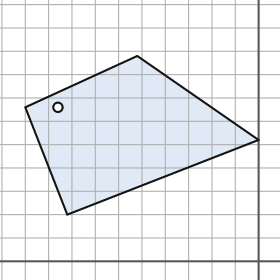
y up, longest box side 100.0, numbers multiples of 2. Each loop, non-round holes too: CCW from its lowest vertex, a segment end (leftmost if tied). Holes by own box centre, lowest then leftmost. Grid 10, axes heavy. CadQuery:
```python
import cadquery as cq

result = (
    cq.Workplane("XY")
    .moveTo(-82.0, 20.0)
    .lineTo(0.0, 52.0)
    .lineTo(-52.0, 88.0)
    .lineTo(-100.0, 66.0)
    .close()
    .moveTo(-86.0, 66.0)
    .circle(2.0)
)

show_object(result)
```